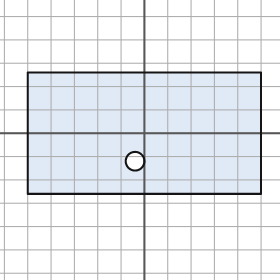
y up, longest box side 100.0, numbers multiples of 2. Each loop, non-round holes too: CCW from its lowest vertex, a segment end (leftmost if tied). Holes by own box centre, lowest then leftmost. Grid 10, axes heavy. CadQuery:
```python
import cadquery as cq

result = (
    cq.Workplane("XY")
    .moveTo(-50.0, -26.0)
    .lineTo(50.0, -26.0)
    .lineTo(50.0, 26.0)
    .lineTo(-50.0, 26.0)
    .close()
    .moveTo(-4.0, -12.0)
    .circle(4.0)
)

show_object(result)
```